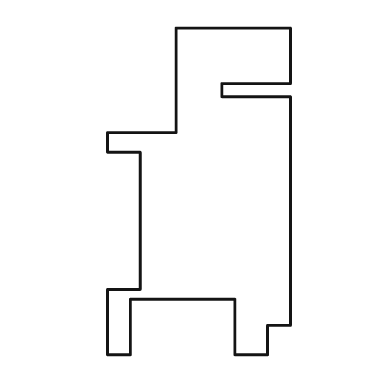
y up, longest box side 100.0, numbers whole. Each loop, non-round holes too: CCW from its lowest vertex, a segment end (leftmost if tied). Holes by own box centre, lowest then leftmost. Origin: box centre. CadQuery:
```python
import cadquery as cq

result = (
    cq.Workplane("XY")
    .moveTo(-28.0, -50.0)
    .lineTo(-21.0, -50.0)
    .lineTo(-21.0, -33.0)
    .lineTo(11.0, -33.0)
    .lineTo(11.0, -50.0)
    .lineTo(21.0, -50.0)
    .lineTo(21.0, -41.0)
    .lineTo(28.0, -41.0)
    .lineTo(28.0, 29.0)
    .lineTo(7.0, 29.0)
    .lineTo(7.0, 33.0)
    .lineTo(28.0, 33.0)
    .lineTo(28.0, 50.0)
    .lineTo(-7.0, 50.0)
    .lineTo(-7.0, 18.0)
    .lineTo(-28.0, 18.0)
    .lineTo(-28.0, 12.0)
    .lineTo(-18.0, 12.0)
    .lineTo(-18.0, -30.0)
    .lineTo(-28.0, -30.0)
    .close()
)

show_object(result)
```